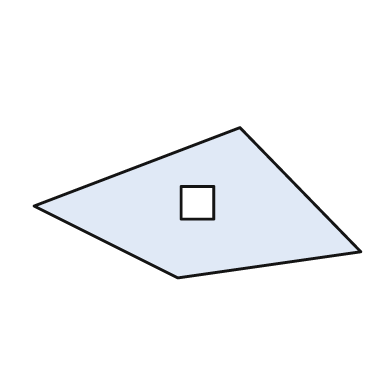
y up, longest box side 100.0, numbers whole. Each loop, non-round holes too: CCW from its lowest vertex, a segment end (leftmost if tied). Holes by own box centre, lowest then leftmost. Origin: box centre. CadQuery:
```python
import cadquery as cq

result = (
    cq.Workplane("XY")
    .moveTo(-6.0, -23.0)
    .lineTo(50.0, -15.0)
    .lineTo(13.0, 23.0)
    .lineTo(-50.0, -1.0)
    .close()
    .moveTo(-5.0, -5.0)
    .lineTo(5.0, -5.0)
    .lineTo(5.0, 5.0)
    .lineTo(-5.0, 5.0)
    .close()
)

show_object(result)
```